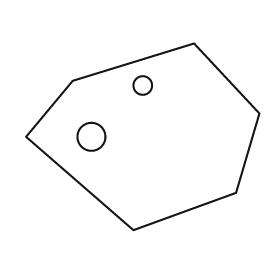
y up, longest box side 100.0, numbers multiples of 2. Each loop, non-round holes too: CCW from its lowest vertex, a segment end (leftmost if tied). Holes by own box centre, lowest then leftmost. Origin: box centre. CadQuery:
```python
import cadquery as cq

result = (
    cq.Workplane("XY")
    .moveTo(-4.0, -40.0)
    .lineTo(40.0, -24.0)
    .lineTo(50.0, 10.0)
    .lineTo(22.0, 40.0)
    .lineTo(-30.0, 24.0)
    .lineTo(-50.0, 0.0)
    .close()
    .moveTo(-22.0, 0.0)
    .circle(6.0)
    .moveTo(0.0, 22.0)
    .circle(4.0)
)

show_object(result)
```